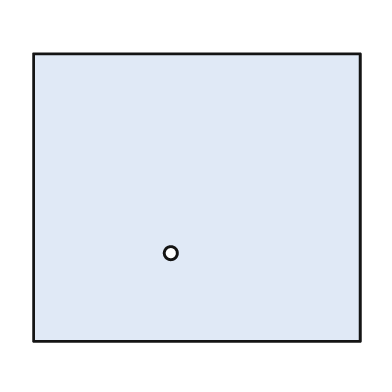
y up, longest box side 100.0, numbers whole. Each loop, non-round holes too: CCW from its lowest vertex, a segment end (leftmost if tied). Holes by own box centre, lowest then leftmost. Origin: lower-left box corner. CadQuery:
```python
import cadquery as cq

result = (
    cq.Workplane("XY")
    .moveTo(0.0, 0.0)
    .lineTo(100.0, 0.0)
    .lineTo(100.0, 88.0)
    .lineTo(0.0, 88.0)
    .close()
    .moveTo(42.0, 27.0)
    .circle(2.0)
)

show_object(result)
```